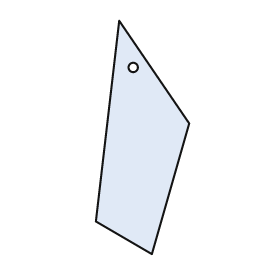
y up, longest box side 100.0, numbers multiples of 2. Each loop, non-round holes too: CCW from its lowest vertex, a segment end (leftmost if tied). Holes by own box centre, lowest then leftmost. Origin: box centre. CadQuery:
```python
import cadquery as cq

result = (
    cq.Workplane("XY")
    .moveTo(4.0, -50.0)
    .lineTo(20.0, 6.0)
    .lineTo(-10.0, 50.0)
    .lineTo(-20.0, -36.0)
    .close()
    .moveTo(-4.0, 30.0)
    .circle(2.0)
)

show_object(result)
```